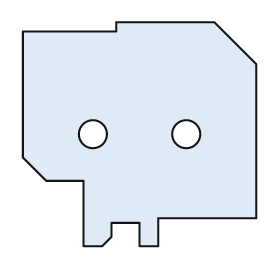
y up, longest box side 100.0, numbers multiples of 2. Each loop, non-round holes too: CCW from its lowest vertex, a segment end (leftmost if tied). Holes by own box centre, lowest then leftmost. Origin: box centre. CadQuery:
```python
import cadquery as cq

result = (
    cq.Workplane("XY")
    .moveTo(-24.0, -48.0)
    .lineTo(-16.0, -48.0)
    .lineTo(-12.0, -44.0)
    .lineTo(-12.0, -38.0)
    .lineTo(0.0, -38.0)
    .lineTo(0.0, -48.0)
    .lineTo(8.0, -48.0)
    .lineTo(8.0, -36.0)
    .lineTo(50.0, -36.0)
    .lineTo(50.0, 30.0)
    .lineTo(32.0, 48.0)
    .lineTo(-10.0, 48.0)
    .lineTo(-10.0, 44.0)
    .lineTo(-50.0, 44.0)
    .lineTo(-50.0, -10.0)
    .lineTo(-40.0, -20.0)
    .lineTo(-24.0, -20.0)
    .close()
    .moveTo(-20.0, 0.0)
    .circle(6.0)
    .moveTo(20.0, 0.0)
    .circle(6.0)
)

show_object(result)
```